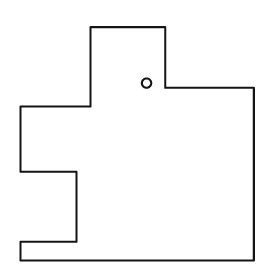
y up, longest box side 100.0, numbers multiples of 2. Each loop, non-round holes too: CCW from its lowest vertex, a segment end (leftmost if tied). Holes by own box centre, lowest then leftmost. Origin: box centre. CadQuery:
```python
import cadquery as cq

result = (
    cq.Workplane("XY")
    .moveTo(-50.0, -50.0)
    .lineTo(50.0, -50.0)
    .lineTo(50.0, 24.0)
    .lineTo(12.0, 24.0)
    .lineTo(12.0, 50.0)
    .lineTo(-20.0, 50.0)
    .lineTo(-20.0, 16.0)
    .lineTo(-50.0, 16.0)
    .lineTo(-50.0, -12.0)
    .lineTo(-26.0, -12.0)
    .lineTo(-26.0, -42.0)
    .lineTo(-50.0, -42.0)
    .close()
    .moveTo(4.0, 26.0)
    .circle(2.0)
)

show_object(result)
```